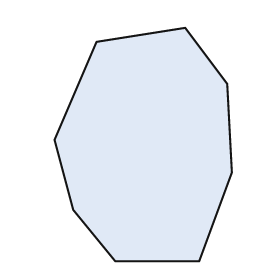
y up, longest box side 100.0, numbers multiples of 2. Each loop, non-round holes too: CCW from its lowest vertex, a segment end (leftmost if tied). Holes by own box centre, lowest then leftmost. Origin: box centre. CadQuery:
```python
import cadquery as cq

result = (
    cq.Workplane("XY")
    .moveTo(-12.0, -50.0)
    .lineTo(24.0, -50.0)
    .lineTo(38.0, -12.0)
    .lineTo(36.0, 26.0)
    .lineTo(18.0, 50.0)
    .lineTo(-20.0, 44.0)
    .lineTo(-38.0, 2.0)
    .lineTo(-30.0, -28.0)
    .close()
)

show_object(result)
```